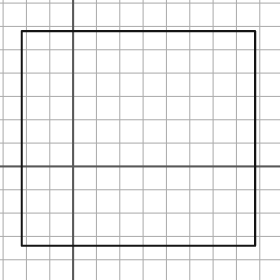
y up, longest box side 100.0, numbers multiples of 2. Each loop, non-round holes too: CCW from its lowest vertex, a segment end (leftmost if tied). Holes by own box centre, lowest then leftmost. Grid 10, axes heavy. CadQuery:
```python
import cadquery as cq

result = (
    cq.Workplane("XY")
    .moveTo(-22.0, -34.0)
    .lineTo(78.0, -34.0)
    .lineTo(78.0, 58.0)
    .lineTo(-22.0, 58.0)
    .close()
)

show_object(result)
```